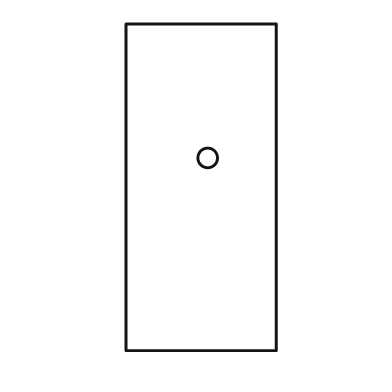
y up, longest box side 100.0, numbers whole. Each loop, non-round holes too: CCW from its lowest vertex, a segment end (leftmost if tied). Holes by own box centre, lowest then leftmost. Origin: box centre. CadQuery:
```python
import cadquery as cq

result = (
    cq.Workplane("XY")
    .moveTo(-23.0, -50.0)
    .lineTo(23.0, -50.0)
    .lineTo(23.0, 50.0)
    .lineTo(-23.0, 50.0)
    .close()
    .moveTo(2.0, 9.0)
    .circle(3.0)
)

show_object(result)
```